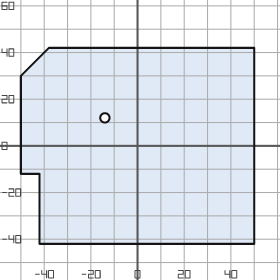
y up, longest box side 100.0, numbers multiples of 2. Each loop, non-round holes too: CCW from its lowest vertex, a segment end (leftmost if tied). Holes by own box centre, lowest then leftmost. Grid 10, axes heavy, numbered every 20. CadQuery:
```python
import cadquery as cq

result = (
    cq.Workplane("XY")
    .moveTo(-42.0, -42.0)
    .lineTo(50.0, -42.0)
    .lineTo(50.0, 42.0)
    .lineTo(-38.0, 42.0)
    .lineTo(-50.0, 30.0)
    .lineTo(-50.0, -12.0)
    .lineTo(-42.0, -12.0)
    .close()
    .moveTo(-14.0, 12.0)
    .circle(2.0)
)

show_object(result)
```